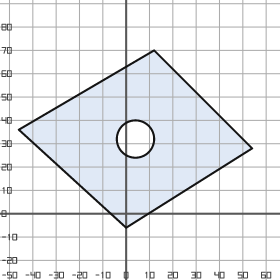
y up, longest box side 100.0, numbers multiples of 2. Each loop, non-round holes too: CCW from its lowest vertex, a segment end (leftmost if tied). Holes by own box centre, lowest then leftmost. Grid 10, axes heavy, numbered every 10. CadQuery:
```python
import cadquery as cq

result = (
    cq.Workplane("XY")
    .moveTo(0.0, -6.0)
    .lineTo(54.0, 28.0)
    .lineTo(12.0, 70.0)
    .lineTo(-46.0, 36.0)
    .close()
    .moveTo(4.0, 32.0)
    .circle(8.0)
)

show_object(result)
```